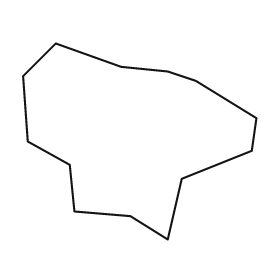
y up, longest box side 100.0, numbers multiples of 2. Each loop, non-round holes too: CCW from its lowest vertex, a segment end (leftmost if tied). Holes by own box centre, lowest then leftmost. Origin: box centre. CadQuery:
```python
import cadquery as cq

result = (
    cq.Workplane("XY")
    .moveTo(12.0, -42.0)
    .lineTo(18.0, -16.0)
    .lineTo(48.0, -4.0)
    .lineTo(50.0, 10.0)
    .lineTo(24.0, 26.0)
    .lineTo(12.0, 30.0)
    .lineTo(-8.0, 32.0)
    .lineTo(-36.0, 42.0)
    .lineTo(-50.0, 28.0)
    .lineTo(-48.0, 0.0)
    .lineTo(-30.0, -10.0)
    .lineTo(-28.0, -30.0)
    .lineTo(-4.0, -32.0)
    .close()
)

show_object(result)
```